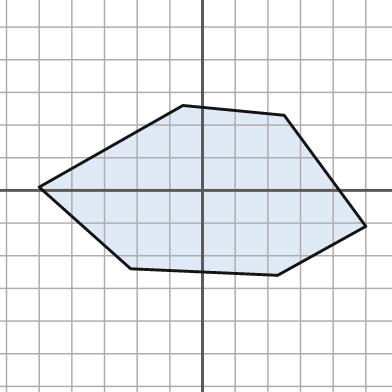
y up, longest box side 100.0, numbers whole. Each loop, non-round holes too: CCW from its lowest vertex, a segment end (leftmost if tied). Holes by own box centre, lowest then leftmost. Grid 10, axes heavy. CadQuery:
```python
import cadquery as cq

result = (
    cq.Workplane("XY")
    .moveTo(23.0, -26.0)
    .lineTo(50.0, -11.0)
    .lineTo(25.0, 23.0)
    .lineTo(-6.0, 26.0)
    .lineTo(-50.0, 1.0)
    .lineTo(-22.0, -24.0)
    .close()
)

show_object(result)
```